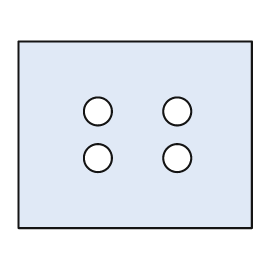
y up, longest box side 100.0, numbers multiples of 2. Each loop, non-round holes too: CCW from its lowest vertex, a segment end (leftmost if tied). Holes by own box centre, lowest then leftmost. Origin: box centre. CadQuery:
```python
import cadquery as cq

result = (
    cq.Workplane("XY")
    .moveTo(-50.0, -40.0)
    .lineTo(50.0, -40.0)
    .lineTo(50.0, 40.0)
    .lineTo(-50.0, 40.0)
    .close()
    .moveTo(-16.0, -10.0)
    .circle(6.0)
    .moveTo(18.0, -10.0)
    .circle(6.0)
    .moveTo(-16.0, 10.0)
    .circle(6.0)
    .moveTo(18.0, 10.0)
    .circle(6.0)
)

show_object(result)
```